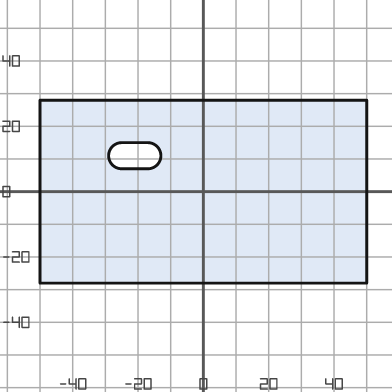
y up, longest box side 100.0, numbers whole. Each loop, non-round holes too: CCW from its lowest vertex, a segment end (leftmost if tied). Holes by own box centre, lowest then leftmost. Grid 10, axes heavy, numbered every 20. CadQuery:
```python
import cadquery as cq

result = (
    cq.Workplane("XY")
    .moveTo(-50.0, -28.0)
    .lineTo(50.0, -28.0)
    .lineTo(50.0, 28.0)
    .lineTo(-50.0, 28.0)
    .close()
    .moveTo(-25.0, 7.0)
    .lineTo(-17.0, 7.0)
    .threePointArc((-13.0, 11.0), (-17.0, 15.0))
    .lineTo(-25.0, 15.0)
    .threePointArc((-29.0, 11.0), (-25.0, 7.0))
    .close()
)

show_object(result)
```